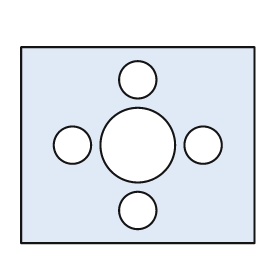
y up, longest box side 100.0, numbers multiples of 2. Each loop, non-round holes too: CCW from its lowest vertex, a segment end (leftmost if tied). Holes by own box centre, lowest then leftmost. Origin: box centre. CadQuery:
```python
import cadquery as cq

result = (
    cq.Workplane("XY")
    .moveTo(-50.0, -42.0)
    .lineTo(50.0, -42.0)
    .lineTo(50.0, 42.0)
    .lineTo(-50.0, 42.0)
    .close()
    .moveTo(0.0, -28.0)
    .circle(8.0)
    .moveTo(-28.0, 0.0)
    .circle(8.0)
    .moveTo(0.0, 0.0)
    .circle(16.0)
    .moveTo(28.0, 0.0)
    .circle(8.0)
    .moveTo(0.0, 28.0)
    .circle(8.0)
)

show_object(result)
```